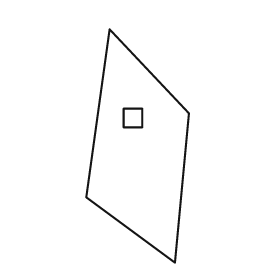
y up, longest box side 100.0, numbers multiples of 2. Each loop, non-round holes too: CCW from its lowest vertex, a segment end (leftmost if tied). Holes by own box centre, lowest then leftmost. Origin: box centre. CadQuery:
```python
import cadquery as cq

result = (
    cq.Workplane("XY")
    .moveTo(16.0, -50.0)
    .lineTo(22.0, 14.0)
    .lineTo(-12.0, 50.0)
    .lineTo(-22.0, -22.0)
    .close()
    .moveTo(-6.0, 8.0)
    .lineTo(2.0, 8.0)
    .lineTo(2.0, 16.0)
    .lineTo(-6.0, 16.0)
    .close()
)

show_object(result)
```